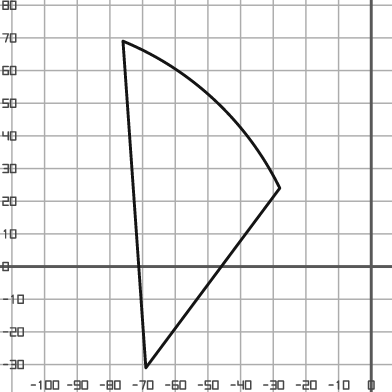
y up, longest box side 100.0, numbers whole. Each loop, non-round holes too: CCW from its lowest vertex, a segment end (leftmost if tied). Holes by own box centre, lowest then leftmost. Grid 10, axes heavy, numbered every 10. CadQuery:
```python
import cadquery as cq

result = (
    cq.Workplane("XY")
    .moveTo(-69.0, -31.0)
    .lineTo(-28.0, 24.0)
    .threePointArc((-48.0, 51.0), (-76.0, 69.0))
    .close()
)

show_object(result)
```